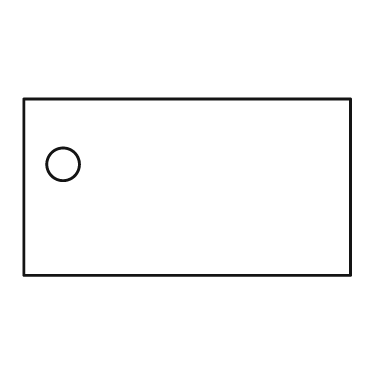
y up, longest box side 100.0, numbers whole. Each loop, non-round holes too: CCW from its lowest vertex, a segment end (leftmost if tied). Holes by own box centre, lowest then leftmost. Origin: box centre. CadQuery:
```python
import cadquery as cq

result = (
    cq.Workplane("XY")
    .moveTo(-50.0, -27.0)
    .lineTo(50.0, -27.0)
    .lineTo(50.0, 27.0)
    .lineTo(-50.0, 27.0)
    .close()
    .moveTo(-38.0, 7.0)
    .circle(5.0)
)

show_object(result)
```